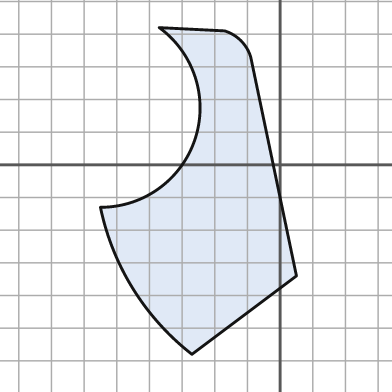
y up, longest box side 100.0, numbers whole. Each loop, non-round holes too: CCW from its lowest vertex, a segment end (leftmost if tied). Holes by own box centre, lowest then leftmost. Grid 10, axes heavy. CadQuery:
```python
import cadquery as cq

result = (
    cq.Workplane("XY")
    .moveTo(-27.0, -58.0)
    .lineTo(5.0, -34.0)
    .lineTo(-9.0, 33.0)
    .threePointArc((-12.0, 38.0), (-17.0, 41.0))
    .lineTo(-37.0, 42.0)
    .threePointArc((-26.0, 8.0), (-55.0, -13.0))
    .threePointArc((-45.0, -38.0), (-27.0, -58.0))
    .close()
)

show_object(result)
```